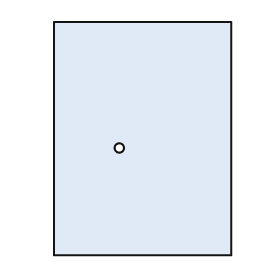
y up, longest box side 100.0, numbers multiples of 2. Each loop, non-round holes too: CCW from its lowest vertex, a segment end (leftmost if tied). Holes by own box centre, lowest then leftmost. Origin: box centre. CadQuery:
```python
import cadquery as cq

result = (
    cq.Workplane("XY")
    .moveTo(-38.0, -50.0)
    .lineTo(38.0, -50.0)
    .lineTo(38.0, 50.0)
    .lineTo(-38.0, 50.0)
    .close()
    .moveTo(-10.0, -4.0)
    .circle(2.0)
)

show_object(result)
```